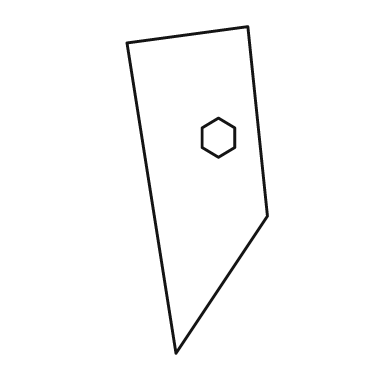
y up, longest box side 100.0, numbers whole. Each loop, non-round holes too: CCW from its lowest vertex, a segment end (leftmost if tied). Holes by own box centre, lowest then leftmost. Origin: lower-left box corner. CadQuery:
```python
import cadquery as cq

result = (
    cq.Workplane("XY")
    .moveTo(15.0, 0.0)
    .lineTo(43.0, 42.0)
    .lineTo(37.0, 100.0)
    .lineTo(0.0, 95.0)
    .close()
    .moveTo(28.0, 60.0)
    .lineTo(33.0, 63.0)
    .lineTo(33.0, 69.0)
    .lineTo(28.0, 72.0)
    .lineTo(23.0, 69.0)
    .lineTo(23.0, 63.0)
    .close()
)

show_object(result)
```